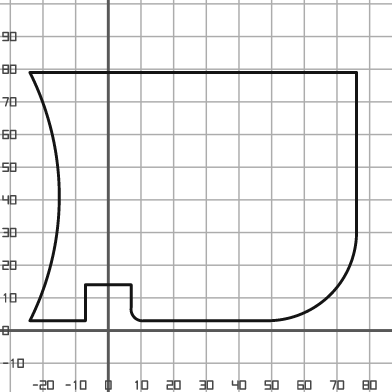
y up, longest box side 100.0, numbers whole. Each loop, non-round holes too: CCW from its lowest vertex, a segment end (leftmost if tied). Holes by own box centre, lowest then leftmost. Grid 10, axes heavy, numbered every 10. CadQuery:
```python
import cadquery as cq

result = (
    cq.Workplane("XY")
    .moveTo(-24.0, 3.0)
    .lineTo(-7.0, 3.0)
    .lineTo(-7.0, 14.0)
    .lineTo(7.0, 14.0)
    .lineTo(7.0, 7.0)
    .threePointArc((8.0, 4.0), (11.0, 3.0))
    .lineTo(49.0, 3.0)
    .threePointArc((68.0, 11.0), (76.0, 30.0))
    .lineTo(76.0, 79.0)
    .lineTo(-24.0, 79.0)
    .threePointArc((-15.0, 41.0), (-24.0, 3.0))
    .close()
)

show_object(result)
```